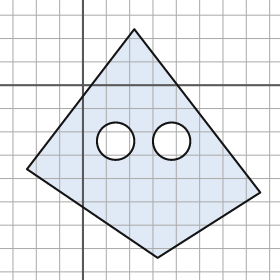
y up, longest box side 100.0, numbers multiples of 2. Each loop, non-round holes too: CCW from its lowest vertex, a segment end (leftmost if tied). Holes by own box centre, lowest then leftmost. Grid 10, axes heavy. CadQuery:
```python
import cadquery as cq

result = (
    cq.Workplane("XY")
    .moveTo(32.0, -74.0)
    .lineTo(76.0, -46.0)
    .lineTo(22.0, 24.0)
    .lineTo(-24.0, -36.0)
    .close()
    .moveTo(14.0, -24.0)
    .circle(8.0)
    .moveTo(38.0, -24.0)
    .circle(8.0)
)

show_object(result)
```